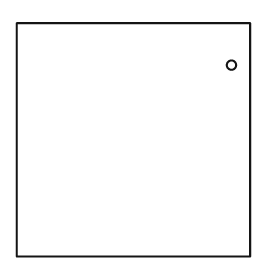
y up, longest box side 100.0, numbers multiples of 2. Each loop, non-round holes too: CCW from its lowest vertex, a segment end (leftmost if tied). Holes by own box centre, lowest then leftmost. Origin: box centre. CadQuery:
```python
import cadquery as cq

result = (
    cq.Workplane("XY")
    .moveTo(-50.0, -50.0)
    .lineTo(50.0, -50.0)
    .lineTo(50.0, 50.0)
    .lineTo(-50.0, 50.0)
    .close()
    .moveTo(42.0, 32.0)
    .circle(2.0)
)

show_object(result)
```